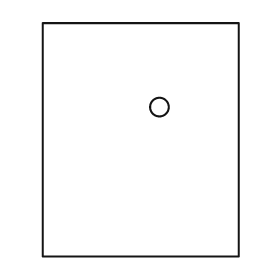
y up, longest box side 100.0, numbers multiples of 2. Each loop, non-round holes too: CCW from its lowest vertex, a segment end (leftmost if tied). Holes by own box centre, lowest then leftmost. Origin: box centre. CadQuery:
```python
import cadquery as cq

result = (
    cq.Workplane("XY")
    .moveTo(-42.0, -50.0)
    .lineTo(42.0, -50.0)
    .lineTo(42.0, 50.0)
    .lineTo(-42.0, 50.0)
    .close()
    .moveTo(8.0, 14.0)
    .circle(4.0)
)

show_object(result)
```